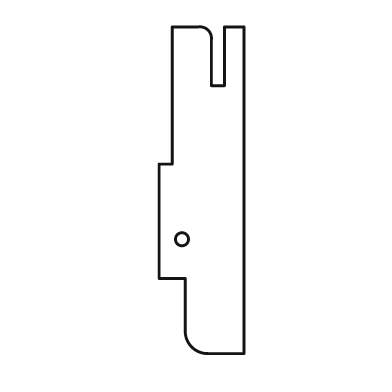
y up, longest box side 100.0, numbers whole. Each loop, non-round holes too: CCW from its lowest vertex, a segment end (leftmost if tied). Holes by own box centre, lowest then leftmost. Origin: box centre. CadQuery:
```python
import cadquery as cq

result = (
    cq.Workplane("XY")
    .moveTo(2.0, -50.0)
    .lineTo(13.0, -50.0)
    .lineTo(13.0, 50.0)
    .lineTo(7.0, 50.0)
    .lineTo(7.0, 32.0)
    .lineTo(3.0, 32.0)
    .lineTo(3.0, 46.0)
    .threePointArc((2.0, 49.0), (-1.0, 50.0))
    .lineTo(-9.0, 50.0)
    .lineTo(-9.0, 8.0)
    .lineTo(-13.0, 8.0)
    .lineTo(-13.0, -27.0)
    .lineTo(-5.0, -27.0)
    .lineTo(-5.0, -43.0)
    .threePointArc((-3.0, -48.0), (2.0, -50.0))
    .close()
    .moveTo(-6.0, -15.0)
    .circle(2.0)
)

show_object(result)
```